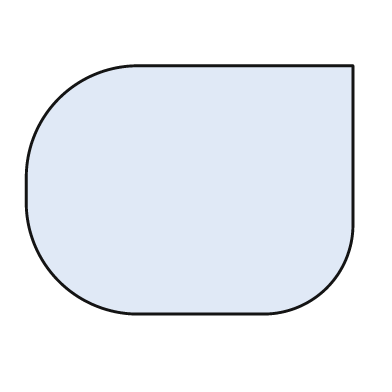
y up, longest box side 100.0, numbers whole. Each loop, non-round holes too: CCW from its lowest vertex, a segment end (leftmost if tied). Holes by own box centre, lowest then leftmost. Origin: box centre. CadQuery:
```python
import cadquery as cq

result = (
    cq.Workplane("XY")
    .moveTo(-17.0, -38.0)
    .lineTo(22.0, -38.0)
    .threePointArc((42.0, -30.0), (50.0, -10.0))
    .lineTo(50.0, 38.0)
    .lineTo(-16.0, 38.0)
    .threePointArc((-40.0, 28.0), (-50.0, 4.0))
    .lineTo(-50.0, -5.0)
    .threePointArc((-40.0, -28.0), (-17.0, -38.0))
    .close()
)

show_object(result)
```